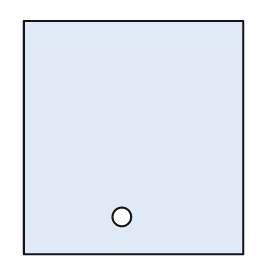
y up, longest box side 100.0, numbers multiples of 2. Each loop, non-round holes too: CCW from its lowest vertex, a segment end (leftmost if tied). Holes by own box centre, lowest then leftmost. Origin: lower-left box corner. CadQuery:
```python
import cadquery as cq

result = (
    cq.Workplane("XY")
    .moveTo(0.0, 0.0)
    .lineTo(94.0, 0.0)
    .lineTo(94.0, 100.0)
    .lineTo(0.0, 100.0)
    .close()
    .moveTo(42.0, 16.0)
    .circle(4.0)
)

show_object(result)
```